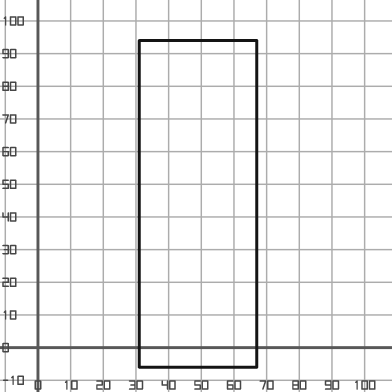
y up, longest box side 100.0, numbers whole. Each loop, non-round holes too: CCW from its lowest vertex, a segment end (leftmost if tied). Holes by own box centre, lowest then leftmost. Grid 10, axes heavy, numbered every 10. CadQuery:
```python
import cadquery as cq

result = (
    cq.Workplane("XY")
    .moveTo(31.0, -6.0)
    .lineTo(67.0, -6.0)
    .lineTo(67.0, 94.0)
    .lineTo(31.0, 94.0)
    .close()
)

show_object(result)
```